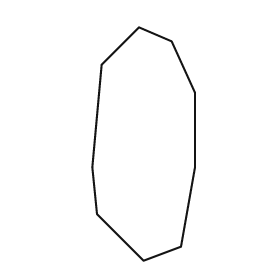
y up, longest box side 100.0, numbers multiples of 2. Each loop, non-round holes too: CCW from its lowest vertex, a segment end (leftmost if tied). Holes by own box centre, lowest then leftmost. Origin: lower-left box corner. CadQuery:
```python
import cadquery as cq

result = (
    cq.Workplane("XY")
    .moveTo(22.0, 0.0)
    .lineTo(38.0, 6.0)
    .lineTo(44.0, 40.0)
    .lineTo(44.0, 72.0)
    .lineTo(34.0, 94.0)
    .lineTo(20.0, 100.0)
    .lineTo(4.0, 84.0)
    .lineTo(0.0, 40.0)
    .lineTo(2.0, 20.0)
    .close()
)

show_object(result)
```